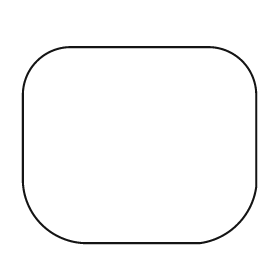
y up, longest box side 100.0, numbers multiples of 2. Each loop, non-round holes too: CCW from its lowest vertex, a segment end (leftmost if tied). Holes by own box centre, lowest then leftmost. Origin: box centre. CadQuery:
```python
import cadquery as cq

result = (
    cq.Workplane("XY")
    .moveTo(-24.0, -42.0)
    .lineTo(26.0, -42.0)
    .threePointArc((42.0, -34.0), (50.0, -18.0))
    .lineTo(50.0, 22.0)
    .threePointArc((44.0, 36.0), (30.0, 42.0))
    .lineTo(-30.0, 42.0)
    .threePointArc((-44.0, 36.0), (-50.0, 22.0))
    .lineTo(-50.0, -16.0)
    .threePointArc((-42.0, -34.0), (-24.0, -42.0))
    .close()
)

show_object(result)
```